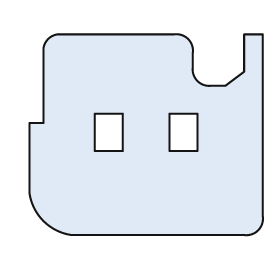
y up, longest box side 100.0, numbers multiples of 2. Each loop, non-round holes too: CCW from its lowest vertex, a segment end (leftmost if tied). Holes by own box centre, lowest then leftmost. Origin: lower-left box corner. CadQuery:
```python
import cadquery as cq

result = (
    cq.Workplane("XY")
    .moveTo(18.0, 0.0)
    .lineTo(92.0, 0.0)
    .threePointArc((98.0, 2.0), (100.0, 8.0))
    .lineTo(100.0, 86.0)
    .lineTo(92.0, 86.0)
    .lineTo(92.0, 70.0)
    .lineTo(84.0, 64.0)
    .lineTo(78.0, 64.0)
    .threePointArc((72.0, 66.0), (70.0, 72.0))
    .lineTo(70.0, 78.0)
    .threePointArc((68.0, 84.0), (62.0, 86.0))
    .lineTo(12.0, 86.0)
    .threePointArc((8.0, 84.0), (6.0, 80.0))
    .lineTo(6.0, 48.0)
    .lineTo(0.0, 48.0)
    .lineTo(0.0, 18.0)
    .threePointArc((6.0, 6.0), (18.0, 0.0))
    .close()
    .moveTo(28.0, 36.0)
    .lineTo(40.0, 36.0)
    .lineTo(40.0, 52.0)
    .lineTo(28.0, 52.0)
    .close()
    .moveTo(60.0, 36.0)
    .lineTo(72.0, 36.0)
    .lineTo(72.0, 52.0)
    .lineTo(60.0, 52.0)
    .close()
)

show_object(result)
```